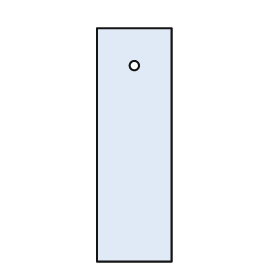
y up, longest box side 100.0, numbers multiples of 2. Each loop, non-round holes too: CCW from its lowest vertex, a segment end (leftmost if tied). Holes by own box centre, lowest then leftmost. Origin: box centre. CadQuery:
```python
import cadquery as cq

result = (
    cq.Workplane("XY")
    .moveTo(-16.0, -50.0)
    .lineTo(16.0, -50.0)
    .lineTo(16.0, 50.0)
    .lineTo(-16.0, 50.0)
    .close()
    .moveTo(0.0, 34.0)
    .circle(2.0)
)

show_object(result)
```